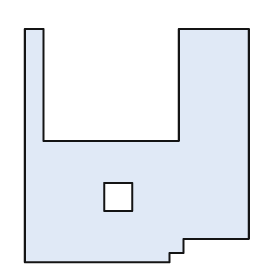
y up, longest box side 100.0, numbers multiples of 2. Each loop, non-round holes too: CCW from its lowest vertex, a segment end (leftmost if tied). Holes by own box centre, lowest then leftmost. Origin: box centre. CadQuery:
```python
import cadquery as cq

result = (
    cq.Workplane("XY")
    .moveTo(-48.0, -50.0)
    .lineTo(14.0, -50.0)
    .lineTo(14.0, -46.0)
    .lineTo(20.0, -46.0)
    .lineTo(20.0, -40.0)
    .lineTo(48.0, -40.0)
    .lineTo(48.0, 50.0)
    .lineTo(18.0, 50.0)
    .lineTo(18.0, 2.0)
    .lineTo(-40.0, 2.0)
    .lineTo(-40.0, 50.0)
    .lineTo(-48.0, 50.0)
    .close()
    .moveTo(-14.0, -28.0)
    .lineTo(-2.0, -28.0)
    .lineTo(-2.0, -16.0)
    .lineTo(-14.0, -16.0)
    .close()
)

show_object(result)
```